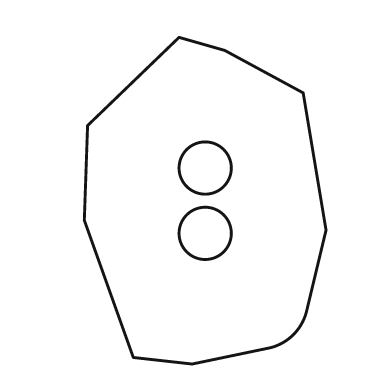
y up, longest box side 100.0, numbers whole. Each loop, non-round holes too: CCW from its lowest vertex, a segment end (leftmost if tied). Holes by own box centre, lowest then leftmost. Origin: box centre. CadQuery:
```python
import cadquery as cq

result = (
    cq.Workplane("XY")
    .moveTo(-4.0, -50.0)
    .lineTo(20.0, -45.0)
    .threePointArc((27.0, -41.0), (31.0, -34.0))
    .lineTo(37.0, -9.0)
    .lineTo(30.0, 33.0)
    .lineTo(6.0, 46.0)
    .lineTo(-8.0, 50.0)
    .lineTo(-36.0, 23.0)
    .lineTo(-37.0, -6.0)
    .lineTo(-22.0, -48.0)
    .close()
    .moveTo(0.0, -10.0)
    .circle(8.0)
    .moveTo(0.0, 10.0)
    .circle(8.0)
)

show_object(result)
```